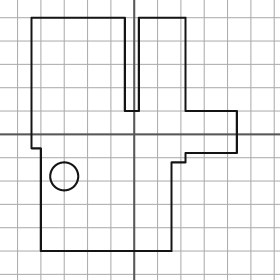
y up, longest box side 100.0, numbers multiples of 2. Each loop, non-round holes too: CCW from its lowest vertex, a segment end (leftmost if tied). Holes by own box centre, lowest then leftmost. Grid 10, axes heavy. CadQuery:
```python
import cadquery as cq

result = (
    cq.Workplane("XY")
    .moveTo(-40.0, -50.0)
    .lineTo(16.0, -50.0)
    .lineTo(16.0, -12.0)
    .lineTo(22.0, -12.0)
    .lineTo(22.0, -8.0)
    .lineTo(44.0, -8.0)
    .lineTo(44.0, 10.0)
    .lineTo(22.0, 10.0)
    .lineTo(22.0, 50.0)
    .lineTo(2.0, 50.0)
    .lineTo(2.0, 10.0)
    .lineTo(-4.0, 10.0)
    .lineTo(-4.0, 50.0)
    .lineTo(-44.0, 50.0)
    .lineTo(-44.0, -6.0)
    .lineTo(-40.0, -6.0)
    .close()
    .moveTo(-30.0, -18.0)
    .circle(6.0)
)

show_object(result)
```